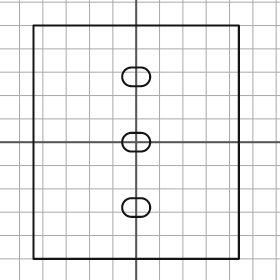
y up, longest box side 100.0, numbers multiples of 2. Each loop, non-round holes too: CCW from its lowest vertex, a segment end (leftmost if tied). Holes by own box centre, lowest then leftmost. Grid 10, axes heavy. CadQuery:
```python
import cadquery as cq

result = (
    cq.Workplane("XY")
    .moveTo(-44.0, -50.0)
    .lineTo(44.0, -50.0)
    .lineTo(44.0, 50.0)
    .lineTo(-44.0, 50.0)
    .close()
    .moveTo(-2.0, -32.0)
    .lineTo(2.0, -32.0)
    .threePointArc((6.0, -28.0), (2.0, -24.0))
    .lineTo(-2.0, -24.0)
    .threePointArc((-6.0, -28.0), (-2.0, -32.0))
    .close()
    .moveTo(-2.0, -4.0)
    .lineTo(2.0, -4.0)
    .threePointArc((6.0, 0.0), (2.0, 4.0))
    .lineTo(-2.0, 4.0)
    .threePointArc((-6.0, 0.0), (-2.0, -4.0))
    .close()
    .moveTo(-2.0, 24.0)
    .lineTo(2.0, 24.0)
    .threePointArc((6.0, 28.0), (2.0, 32.0))
    .lineTo(-2.0, 32.0)
    .threePointArc((-6.0, 28.0), (-2.0, 24.0))
    .close()
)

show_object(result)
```